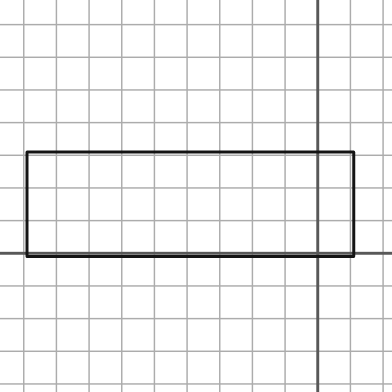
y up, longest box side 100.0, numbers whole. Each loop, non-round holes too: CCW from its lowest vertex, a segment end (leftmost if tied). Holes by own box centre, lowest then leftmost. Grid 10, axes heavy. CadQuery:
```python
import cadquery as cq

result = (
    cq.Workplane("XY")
    .moveTo(-89.0, -1.0)
    .lineTo(11.0, -1.0)
    .lineTo(11.0, 31.0)
    .lineTo(-89.0, 31.0)
    .close()
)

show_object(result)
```